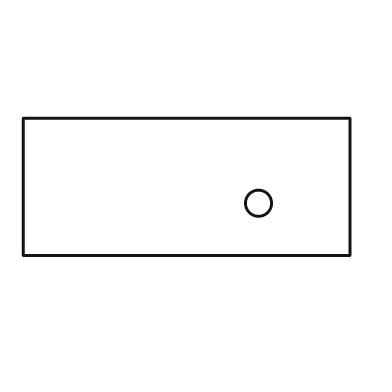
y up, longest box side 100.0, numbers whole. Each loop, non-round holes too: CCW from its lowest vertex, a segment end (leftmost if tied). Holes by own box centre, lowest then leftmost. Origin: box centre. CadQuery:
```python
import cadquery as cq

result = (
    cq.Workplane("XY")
    .moveTo(-50.0, -21.0)
    .lineTo(50.0, -21.0)
    .lineTo(50.0, 21.0)
    .lineTo(-50.0, 21.0)
    .close()
    .moveTo(22.0, -5.0)
    .circle(4.0)
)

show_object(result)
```